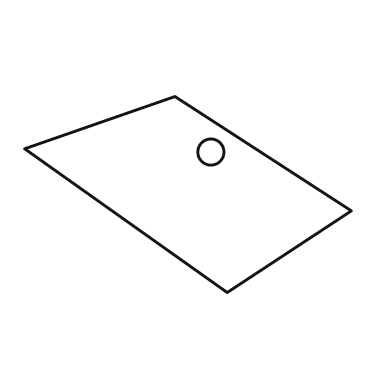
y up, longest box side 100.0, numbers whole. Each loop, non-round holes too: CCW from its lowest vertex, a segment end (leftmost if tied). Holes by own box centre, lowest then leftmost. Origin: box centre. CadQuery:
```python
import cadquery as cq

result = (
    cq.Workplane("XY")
    .moveTo(12.0, -30.0)
    .lineTo(50.0, -5.0)
    .lineTo(-4.0, 30.0)
    .lineTo(-50.0, 14.0)
    .close()
    .moveTo(7.0, 13.0)
    .circle(4.0)
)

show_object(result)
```